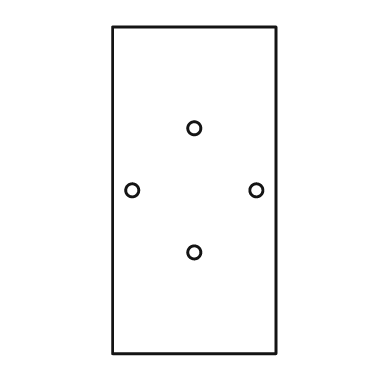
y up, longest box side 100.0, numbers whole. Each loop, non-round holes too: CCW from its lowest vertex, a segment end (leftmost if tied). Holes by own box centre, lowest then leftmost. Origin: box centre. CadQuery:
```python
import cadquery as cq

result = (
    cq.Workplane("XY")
    .moveTo(-25.0, -50.0)
    .lineTo(25.0, -50.0)
    .lineTo(25.0, 50.0)
    .lineTo(-25.0, 50.0)
    .close()
    .moveTo(0.0, -19.0)
    .circle(2.0)
    .moveTo(-19.0, 0.0)
    .circle(2.0)
    .moveTo(19.0, 0.0)
    .circle(2.0)
    .moveTo(0.0, 19.0)
    .circle(2.0)
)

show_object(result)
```